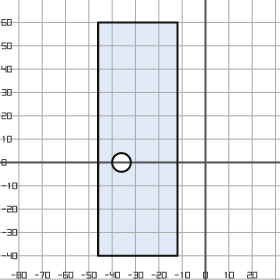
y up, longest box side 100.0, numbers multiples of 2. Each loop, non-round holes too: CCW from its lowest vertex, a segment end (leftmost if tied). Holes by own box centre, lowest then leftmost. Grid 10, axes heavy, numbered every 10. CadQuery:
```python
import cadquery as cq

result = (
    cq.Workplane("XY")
    .moveTo(-46.0, -40.0)
    .lineTo(-12.0, -40.0)
    .lineTo(-12.0, 60.0)
    .lineTo(-46.0, 60.0)
    .close()
    .moveTo(-36.0, 0.0)
    .circle(4.0)
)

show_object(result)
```